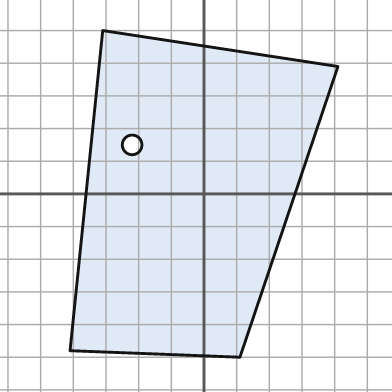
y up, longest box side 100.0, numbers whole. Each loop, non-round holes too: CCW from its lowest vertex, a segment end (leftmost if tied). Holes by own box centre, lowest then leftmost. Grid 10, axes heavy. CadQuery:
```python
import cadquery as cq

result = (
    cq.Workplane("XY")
    .moveTo(11.0, -50.0)
    .lineTo(41.0, 39.0)
    .lineTo(-31.0, 50.0)
    .lineTo(-41.0, -48.0)
    .close()
    .moveTo(-22.0, 15.0)
    .circle(3.0)
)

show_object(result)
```